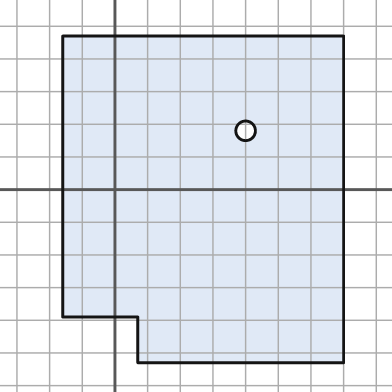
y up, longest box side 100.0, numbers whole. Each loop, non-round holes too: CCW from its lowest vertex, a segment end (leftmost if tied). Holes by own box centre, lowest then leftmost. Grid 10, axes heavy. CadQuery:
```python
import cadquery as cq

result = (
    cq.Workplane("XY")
    .moveTo(7.0, -53.0)
    .lineTo(70.0, -53.0)
    .lineTo(70.0, 47.0)
    .lineTo(-16.0, 47.0)
    .lineTo(-16.0, -39.0)
    .lineTo(7.0, -39.0)
    .close()
    .moveTo(40.0, 18.0)
    .circle(3.0)
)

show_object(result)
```